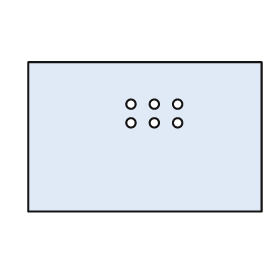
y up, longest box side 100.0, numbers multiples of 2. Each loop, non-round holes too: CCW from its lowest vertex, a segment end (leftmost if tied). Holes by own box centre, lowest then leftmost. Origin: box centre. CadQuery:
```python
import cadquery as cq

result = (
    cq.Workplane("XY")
    .moveTo(-50.0, -32.0)
    .lineTo(50.0, -32.0)
    .lineTo(50.0, 32.0)
    .lineTo(-50.0, 32.0)
    .close()
    .moveTo(-6.0, 6.0)
    .circle(2.0)
    .moveTo(4.0, 6.0)
    .circle(2.0)
    .moveTo(14.0, 6.0)
    .circle(2.0)
    .moveTo(-6.0, 14.0)
    .circle(2.0)
    .moveTo(4.0, 14.0)
    .circle(2.0)
    .moveTo(14.0, 14.0)
    .circle(2.0)
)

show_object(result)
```